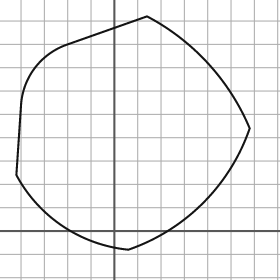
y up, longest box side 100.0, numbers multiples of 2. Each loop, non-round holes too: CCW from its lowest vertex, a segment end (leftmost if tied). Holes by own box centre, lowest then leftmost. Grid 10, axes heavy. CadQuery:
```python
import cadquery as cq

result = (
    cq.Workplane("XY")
    .moveTo(6.0, -8.0)
    .threePointArc((38.0, 12.0), (58.0, 44.0))
    .threePointArc((40.0, 72.0), (14.0, 92.0))
    .lineTo(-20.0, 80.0)
    .threePointArc((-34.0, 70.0), (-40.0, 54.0))
    .lineTo(-42.0, 24.0)
    .threePointArc((-22.0, 2.0), (6.0, -8.0))
    .close()
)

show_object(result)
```